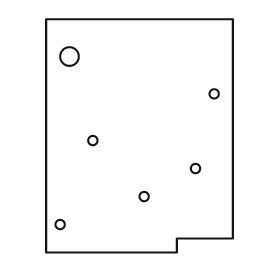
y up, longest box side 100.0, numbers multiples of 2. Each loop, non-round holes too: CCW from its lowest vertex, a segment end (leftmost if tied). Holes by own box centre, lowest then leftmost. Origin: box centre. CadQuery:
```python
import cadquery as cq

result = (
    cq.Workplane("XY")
    .moveTo(-40.0, -50.0)
    .lineTo(16.0, -50.0)
    .lineTo(16.0, -44.0)
    .lineTo(40.0, -44.0)
    .lineTo(40.0, 50.0)
    .lineTo(-40.0, 50.0)
    .close()
    .moveTo(-34.0, -38.0)
    .circle(2.0)
    .moveTo(2.0, -26.0)
    .circle(2.0)
    .moveTo(24.0, -14.0)
    .circle(2.0)
    .moveTo(-20.0, -2.0)
    .circle(2.0)
    .moveTo(32.0, 18.0)
    .circle(2.0)
    .moveTo(-30.0, 34.0)
    .circle(4.0)
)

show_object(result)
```